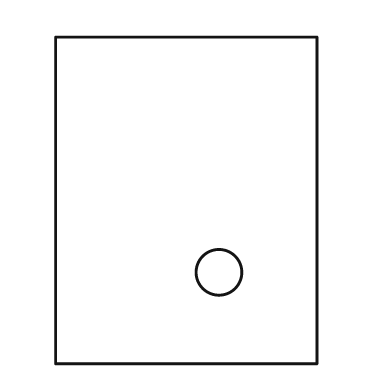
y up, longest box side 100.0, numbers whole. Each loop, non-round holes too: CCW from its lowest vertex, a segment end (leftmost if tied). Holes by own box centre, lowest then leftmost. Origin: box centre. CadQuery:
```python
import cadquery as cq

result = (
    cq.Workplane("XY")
    .moveTo(-40.0, -50.0)
    .lineTo(40.0, -50.0)
    .lineTo(40.0, 50.0)
    .lineTo(-40.0, 50.0)
    .close()
    .moveTo(10.0, -22.0)
    .circle(7.0)
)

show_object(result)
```